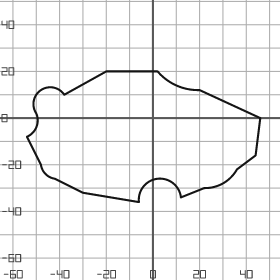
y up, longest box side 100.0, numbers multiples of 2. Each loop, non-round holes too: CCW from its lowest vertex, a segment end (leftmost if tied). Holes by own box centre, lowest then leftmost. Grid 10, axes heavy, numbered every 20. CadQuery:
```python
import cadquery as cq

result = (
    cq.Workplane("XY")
    .moveTo(-6.0, -36.0)
    .threePointArc((2.0, -26.0), (12.0, -34.0))
    .lineTo(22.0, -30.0)
    .threePointArc((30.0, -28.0), (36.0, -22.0))
    .lineTo(44.0, -16.0)
    .lineTo(46.0, 0.0)
    .lineTo(20.0, 12.0)
    .threePointArc((10.0, 14.0), (2.0, 20.0))
    .lineTo(-20.0, 20.0)
    .lineTo(-38.0, 10.0)
    .threePointArc((-48.0, 12.0), (-50.0, 2.0))
    .threePointArc((-50.0, -4.0), (-54.0, -8.0))
    .lineTo(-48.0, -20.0)
    .threePointArc((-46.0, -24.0), (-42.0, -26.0))
    .lineTo(-30.0, -32.0)
    .close()
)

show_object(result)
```